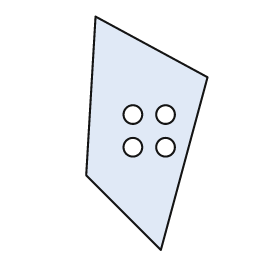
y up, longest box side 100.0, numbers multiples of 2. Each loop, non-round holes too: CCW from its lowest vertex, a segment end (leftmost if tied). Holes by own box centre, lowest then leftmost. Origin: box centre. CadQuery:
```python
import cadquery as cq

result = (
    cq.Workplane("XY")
    .moveTo(6.0, -50.0)
    .lineTo(26.0, 24.0)
    .lineTo(-22.0, 50.0)
    .lineTo(-26.0, -18.0)
    .close()
    .moveTo(-6.0, -6.0)
    .circle(4.0)
    .moveTo(8.0, -6.0)
    .circle(4.0)
    .moveTo(-6.0, 8.0)
    .circle(4.0)
    .moveTo(8.0, 8.0)
    .circle(4.0)
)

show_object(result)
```